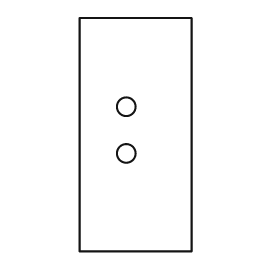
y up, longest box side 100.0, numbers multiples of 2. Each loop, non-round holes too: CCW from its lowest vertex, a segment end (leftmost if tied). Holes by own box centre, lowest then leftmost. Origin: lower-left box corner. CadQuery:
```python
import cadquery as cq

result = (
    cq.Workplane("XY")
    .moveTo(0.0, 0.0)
    .lineTo(48.0, 0.0)
    .lineTo(48.0, 100.0)
    .lineTo(0.0, 100.0)
    .close()
    .moveTo(20.0, 42.0)
    .circle(4.0)
    .moveTo(20.0, 62.0)
    .circle(4.0)
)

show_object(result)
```